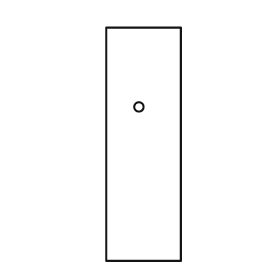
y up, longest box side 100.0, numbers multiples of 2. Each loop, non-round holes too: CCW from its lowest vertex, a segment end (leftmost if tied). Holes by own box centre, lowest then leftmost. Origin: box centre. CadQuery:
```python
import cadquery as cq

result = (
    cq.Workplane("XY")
    .moveTo(-16.0, -50.0)
    .lineTo(16.0, -50.0)
    .lineTo(16.0, 50.0)
    .lineTo(-16.0, 50.0)
    .close()
    .moveTo(-2.0, 16.0)
    .circle(2.0)
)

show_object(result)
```